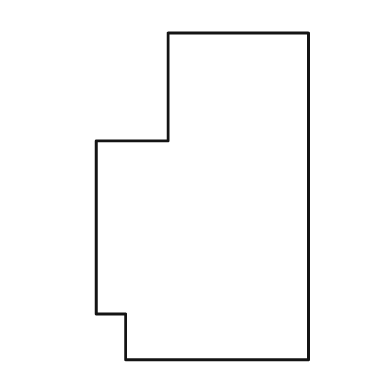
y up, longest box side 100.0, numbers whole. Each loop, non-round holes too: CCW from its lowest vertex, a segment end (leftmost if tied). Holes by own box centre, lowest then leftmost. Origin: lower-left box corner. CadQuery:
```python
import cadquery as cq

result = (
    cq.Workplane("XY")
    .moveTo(9.0, 0.0)
    .lineTo(65.0, 0.0)
    .lineTo(65.0, 100.0)
    .lineTo(22.0, 100.0)
    .lineTo(22.0, 67.0)
    .lineTo(0.0, 67.0)
    .lineTo(0.0, 14.0)
    .lineTo(9.0, 14.0)
    .close()
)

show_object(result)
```